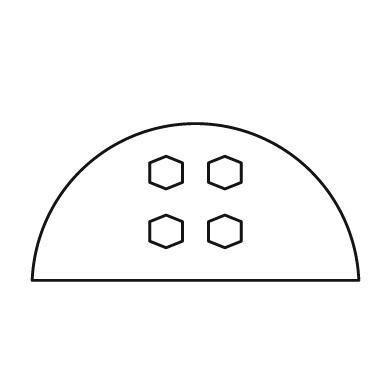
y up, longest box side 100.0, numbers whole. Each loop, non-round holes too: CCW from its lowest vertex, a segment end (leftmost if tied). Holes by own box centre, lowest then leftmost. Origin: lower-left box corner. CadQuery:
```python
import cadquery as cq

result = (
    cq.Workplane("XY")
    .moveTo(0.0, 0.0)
    .lineTo(100.0, 0.0)
    .threePointArc((50.0, 48.0), (0.0, 0.0))
    .close()
    .moveTo(41.0, 10.0)
    .lineTo(46.0, 12.0)
    .lineTo(46.0, 18.0)
    .lineTo(41.0, 20.0)
    .lineTo(36.0, 18.0)
    .lineTo(36.0, 12.0)
    .close()
    .moveTo(59.0, 10.0)
    .lineTo(64.0, 12.0)
    .lineTo(64.0, 18.0)
    .lineTo(59.0, 20.0)
    .lineTo(54.0, 18.0)
    .lineTo(54.0, 12.0)
    .close()
    .moveTo(41.0, 28.0)
    .lineTo(46.0, 30.0)
    .lineTo(46.0, 36.0)
    .lineTo(41.0, 38.0)
    .lineTo(36.0, 36.0)
    .lineTo(36.0, 30.0)
    .close()
    .moveTo(59.0, 28.0)
    .lineTo(64.0, 30.0)
    .lineTo(64.0, 36.0)
    .lineTo(59.0, 38.0)
    .lineTo(54.0, 36.0)
    .lineTo(54.0, 30.0)
    .close()
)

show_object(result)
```